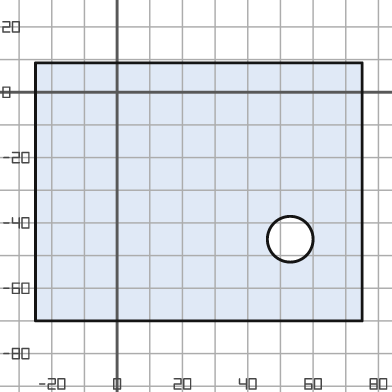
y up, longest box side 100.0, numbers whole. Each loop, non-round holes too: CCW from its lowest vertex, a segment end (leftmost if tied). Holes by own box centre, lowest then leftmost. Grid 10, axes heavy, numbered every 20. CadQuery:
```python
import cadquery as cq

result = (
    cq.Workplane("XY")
    .moveTo(-25.0, -70.0)
    .lineTo(75.0, -70.0)
    .lineTo(75.0, 9.0)
    .lineTo(-25.0, 9.0)
    .close()
    .moveTo(53.0, -45.0)
    .circle(7.0)
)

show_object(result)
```